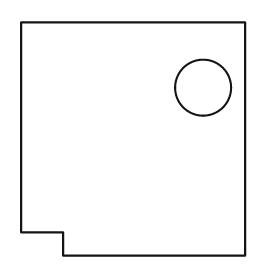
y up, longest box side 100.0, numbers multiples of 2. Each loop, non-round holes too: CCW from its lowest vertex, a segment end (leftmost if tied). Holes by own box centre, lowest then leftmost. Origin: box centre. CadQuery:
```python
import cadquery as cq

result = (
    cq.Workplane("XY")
    .moveTo(-30.0, -50.0)
    .lineTo(48.0, -50.0)
    .lineTo(48.0, 50.0)
    .lineTo(-48.0, 50.0)
    .lineTo(-48.0, -40.0)
    .lineTo(-30.0, -40.0)
    .close()
    .moveTo(30.0, 22.0)
    .circle(12.0)
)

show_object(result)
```